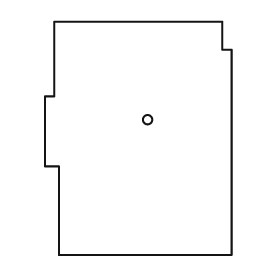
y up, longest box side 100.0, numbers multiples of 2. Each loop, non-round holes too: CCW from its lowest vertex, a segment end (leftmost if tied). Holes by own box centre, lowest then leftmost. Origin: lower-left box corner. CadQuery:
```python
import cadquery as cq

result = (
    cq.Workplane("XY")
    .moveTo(6.0, 0.0)
    .lineTo(80.0, 0.0)
    .lineTo(80.0, 88.0)
    .lineTo(76.0, 88.0)
    .lineTo(76.0, 100.0)
    .lineTo(4.0, 100.0)
    .lineTo(4.0, 68.0)
    .lineTo(0.0, 68.0)
    .lineTo(0.0, 38.0)
    .lineTo(6.0, 38.0)
    .close()
    .moveTo(44.0, 58.0)
    .circle(2.0)
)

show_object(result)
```